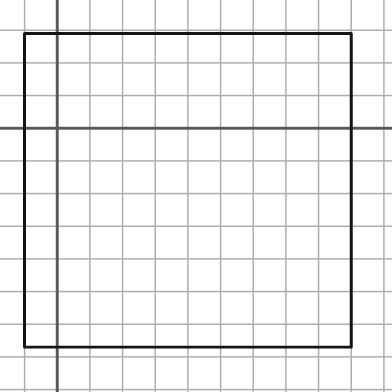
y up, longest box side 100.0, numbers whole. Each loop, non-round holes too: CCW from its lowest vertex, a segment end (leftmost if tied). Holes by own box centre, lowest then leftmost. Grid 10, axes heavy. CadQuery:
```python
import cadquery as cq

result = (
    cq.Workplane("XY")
    .moveTo(-10.0, -67.0)
    .lineTo(90.0, -67.0)
    .lineTo(90.0, 29.0)
    .lineTo(-10.0, 29.0)
    .close()
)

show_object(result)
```